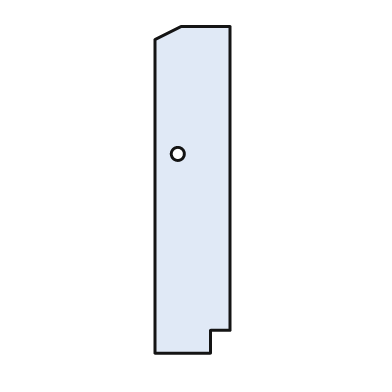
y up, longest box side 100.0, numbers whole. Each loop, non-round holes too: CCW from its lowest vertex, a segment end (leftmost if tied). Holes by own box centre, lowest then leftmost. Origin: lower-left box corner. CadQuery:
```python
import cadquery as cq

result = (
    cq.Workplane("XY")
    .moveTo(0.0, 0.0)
    .lineTo(17.0, 0.0)
    .lineTo(17.0, 7.0)
    .lineTo(23.0, 7.0)
    .lineTo(23.0, 100.0)
    .lineTo(8.0, 100.0)
    .lineTo(0.0, 96.0)
    .close()
    .moveTo(7.0, 61.0)
    .circle(2.0)
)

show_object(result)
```